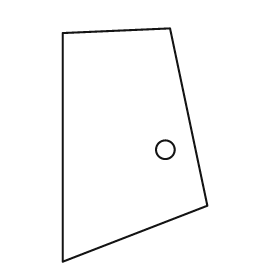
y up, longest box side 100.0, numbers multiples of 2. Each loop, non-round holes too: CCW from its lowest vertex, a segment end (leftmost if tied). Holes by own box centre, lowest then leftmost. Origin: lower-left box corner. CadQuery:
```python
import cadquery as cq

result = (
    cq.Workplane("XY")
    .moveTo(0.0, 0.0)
    .lineTo(62.0, 24.0)
    .lineTo(46.0, 100.0)
    .lineTo(0.0, 98.0)
    .close()
    .moveTo(44.0, 48.0)
    .circle(4.0)
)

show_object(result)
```